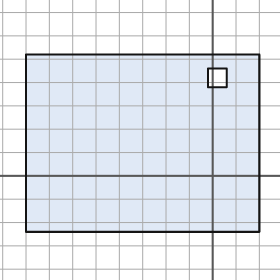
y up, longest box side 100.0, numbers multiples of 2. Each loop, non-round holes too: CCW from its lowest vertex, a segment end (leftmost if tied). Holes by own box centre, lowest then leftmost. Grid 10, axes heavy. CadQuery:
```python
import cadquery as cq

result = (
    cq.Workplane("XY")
    .moveTo(-80.0, -24.0)
    .lineTo(20.0, -24.0)
    .lineTo(20.0, 52.0)
    .lineTo(-80.0, 52.0)
    .close()
    .moveTo(-2.0, 38.0)
    .lineTo(6.0, 38.0)
    .lineTo(6.0, 46.0)
    .lineTo(-2.0, 46.0)
    .close()
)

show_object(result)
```